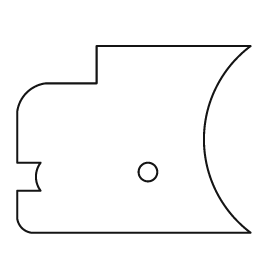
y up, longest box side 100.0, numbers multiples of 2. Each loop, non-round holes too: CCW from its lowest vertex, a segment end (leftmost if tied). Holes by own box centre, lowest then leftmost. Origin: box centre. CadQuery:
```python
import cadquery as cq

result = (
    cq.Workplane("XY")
    .moveTo(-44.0, -40.0)
    .lineTo(50.0, -40.0)
    .threePointArc((30.0, 0.0), (50.0, 40.0))
    .lineTo(-16.0, 40.0)
    .lineTo(-16.0, 24.0)
    .lineTo(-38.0, 24.0)
    .threePointArc((-46.0, 20.0), (-50.0, 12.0))
    .lineTo(-50.0, -10.0)
    .lineTo(-40.0, -10.0)
    .threePointArc((-42.0, -16.0), (-40.0, -22.0))
    .lineTo(-50.0, -22.0)
    .lineTo(-50.0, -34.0)
    .threePointArc((-48.0, -38.0), (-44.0, -40.0))
    .close()
    .moveTo(6.0, -14.0)
    .circle(4.0)
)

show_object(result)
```